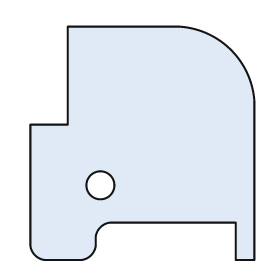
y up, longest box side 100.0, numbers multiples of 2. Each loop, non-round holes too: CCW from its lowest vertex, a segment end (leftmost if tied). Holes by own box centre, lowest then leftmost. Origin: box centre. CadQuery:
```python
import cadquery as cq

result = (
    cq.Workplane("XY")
    .moveTo(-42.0, -50.0)
    .lineTo(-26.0, -50.0)
    .threePointArc((-22.0, -48.0), (-20.0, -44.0))
    .lineTo(-20.0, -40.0)
    .threePointArc((-18.0, -36.0), (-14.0, -34.0))
    .lineTo(40.0, -34.0)
    .lineTo(40.0, -50.0)
    .lineTo(48.0, -50.0)
    .lineTo(48.0, 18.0)
    .threePointArc((38.0, 40.0), (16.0, 50.0))
    .lineTo(-32.0, 50.0)
    .lineTo(-32.0, 8.0)
    .lineTo(-48.0, 8.0)
    .lineTo(-48.0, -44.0)
    .threePointArc((-46.0, -48.0), (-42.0, -50.0))
    .close()
    .moveTo(-18.0, -18.0)
    .circle(6.0)
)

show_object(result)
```